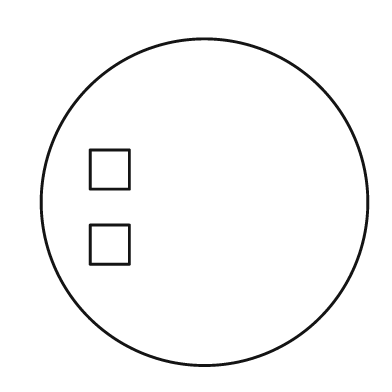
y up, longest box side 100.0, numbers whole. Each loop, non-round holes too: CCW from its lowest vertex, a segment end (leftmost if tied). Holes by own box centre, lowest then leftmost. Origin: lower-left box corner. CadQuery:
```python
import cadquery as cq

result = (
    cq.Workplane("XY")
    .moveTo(50.0, 50.0)
    .circle(50.0)
    .moveTo(15.0, 31.0)
    .lineTo(27.0, 31.0)
    .lineTo(27.0, 43.0)
    .lineTo(15.0, 43.0)
    .close()
    .moveTo(15.0, 54.0)
    .lineTo(27.0, 54.0)
    .lineTo(27.0, 66.0)
    .lineTo(15.0, 66.0)
    .close()
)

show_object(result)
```